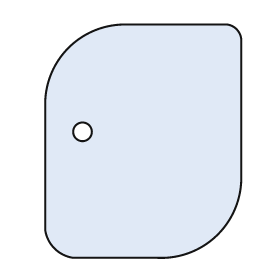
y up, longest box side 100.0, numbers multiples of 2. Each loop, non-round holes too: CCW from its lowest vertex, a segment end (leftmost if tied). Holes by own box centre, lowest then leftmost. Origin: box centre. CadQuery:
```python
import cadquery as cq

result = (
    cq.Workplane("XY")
    .moveTo(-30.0, -50.0)
    .lineTo(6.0, -50.0)
    .threePointArc((32.0, -40.0), (42.0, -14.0))
    .lineTo(42.0, 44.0)
    .threePointArc((40.0, 48.0), (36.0, 50.0))
    .lineTo(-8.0, 50.0)
    .threePointArc((-32.0, 40.0), (-42.0, 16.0))
    .lineTo(-42.0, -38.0)
    .threePointArc((-38.0, -46.0), (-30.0, -50.0))
    .close()
    .moveTo(-26.0, 4.0)
    .circle(4.0)
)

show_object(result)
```